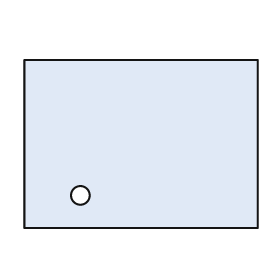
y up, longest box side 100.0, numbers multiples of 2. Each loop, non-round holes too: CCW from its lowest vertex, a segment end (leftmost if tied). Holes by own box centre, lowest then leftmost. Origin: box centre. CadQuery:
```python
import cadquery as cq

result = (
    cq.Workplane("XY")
    .moveTo(-50.0, -36.0)
    .lineTo(50.0, -36.0)
    .lineTo(50.0, 36.0)
    .lineTo(-50.0, 36.0)
    .close()
    .moveTo(-26.0, -22.0)
    .circle(4.0)
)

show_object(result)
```